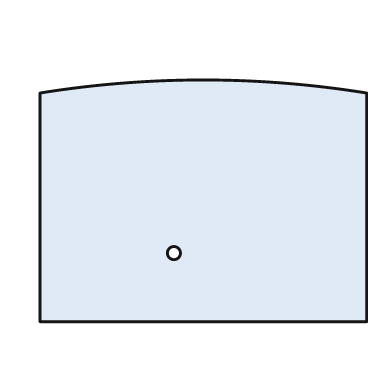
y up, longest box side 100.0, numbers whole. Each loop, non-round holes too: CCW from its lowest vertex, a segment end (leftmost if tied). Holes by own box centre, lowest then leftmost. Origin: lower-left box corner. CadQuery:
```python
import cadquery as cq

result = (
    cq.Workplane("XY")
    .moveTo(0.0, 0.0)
    .lineTo(100.0, 0.0)
    .lineTo(100.0, 70.0)
    .threePointArc((50.0, 74.0), (0.0, 70.0))
    .close()
    .moveTo(41.0, 21.0)
    .circle(2.0)
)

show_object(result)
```